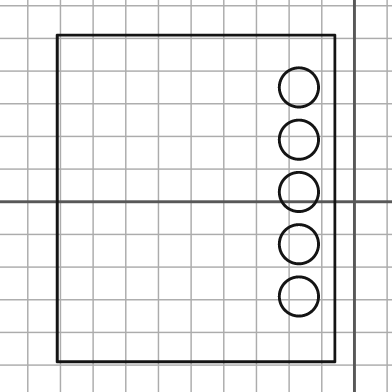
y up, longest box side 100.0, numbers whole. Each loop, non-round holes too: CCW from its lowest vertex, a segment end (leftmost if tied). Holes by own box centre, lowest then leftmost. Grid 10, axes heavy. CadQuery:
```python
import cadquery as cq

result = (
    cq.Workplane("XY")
    .moveTo(-91.0, -49.0)
    .lineTo(-6.0, -49.0)
    .lineTo(-6.0, 51.0)
    .lineTo(-91.0, 51.0)
    .close()
    .moveTo(-17.0, -29.0)
    .circle(6.0)
    .moveTo(-17.0, -13.0)
    .circle(6.0)
    .moveTo(-17.0, 3.0)
    .circle(6.0)
    .moveTo(-17.0, 19.0)
    .circle(6.0)
    .moveTo(-17.0, 35.0)
    .circle(6.0)
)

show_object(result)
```